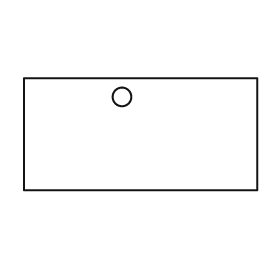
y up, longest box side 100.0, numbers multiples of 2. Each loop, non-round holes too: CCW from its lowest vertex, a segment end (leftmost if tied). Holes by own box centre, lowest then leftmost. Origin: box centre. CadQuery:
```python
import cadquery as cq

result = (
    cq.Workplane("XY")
    .moveTo(-50.0, -24.0)
    .lineTo(50.0, -24.0)
    .lineTo(50.0, 24.0)
    .lineTo(-50.0, 24.0)
    .close()
    .moveTo(-8.0, 16.0)
    .circle(4.0)
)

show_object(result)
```